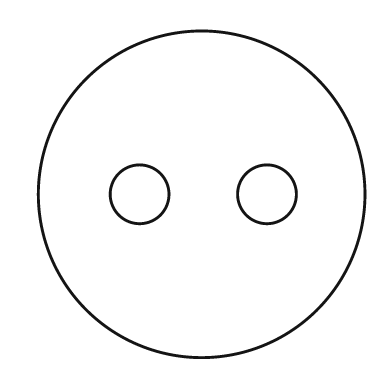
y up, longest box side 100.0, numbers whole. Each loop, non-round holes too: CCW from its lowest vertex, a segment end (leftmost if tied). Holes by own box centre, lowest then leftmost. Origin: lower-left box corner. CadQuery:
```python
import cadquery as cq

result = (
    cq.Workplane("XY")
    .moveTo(50.0, 50.0)
    .circle(50.0)
    .moveTo(31.0, 50.0)
    .circle(9.0)
    .moveTo(70.0, 50.0)
    .circle(9.0)
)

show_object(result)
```